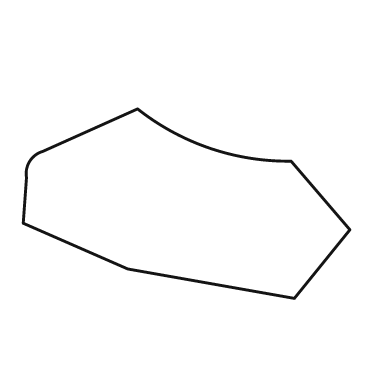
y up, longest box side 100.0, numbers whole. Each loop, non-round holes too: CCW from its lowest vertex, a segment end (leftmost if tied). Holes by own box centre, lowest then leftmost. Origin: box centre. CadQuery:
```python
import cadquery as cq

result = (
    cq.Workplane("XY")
    .moveTo(33.0, -29.0)
    .lineTo(50.0, -8.0)
    .lineTo(32.0, 13.0)
    .threePointArc((7.0, 17.0), (-15.0, 29.0))
    .lineTo(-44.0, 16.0)
    .threePointArc((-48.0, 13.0), (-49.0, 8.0))
    .lineTo(-50.0, -6.0)
    .lineTo(-18.0, -20.0)
    .close()
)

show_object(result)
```